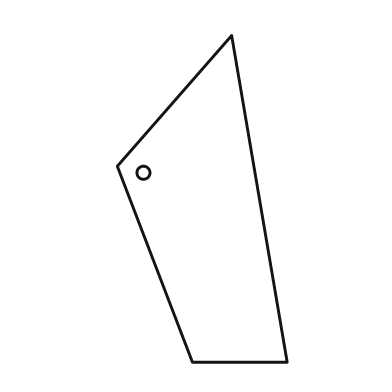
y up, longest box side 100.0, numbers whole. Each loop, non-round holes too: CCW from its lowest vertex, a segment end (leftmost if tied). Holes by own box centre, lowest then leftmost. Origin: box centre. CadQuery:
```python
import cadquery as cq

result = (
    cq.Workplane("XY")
    .moveTo(-3.0, -50.0)
    .lineTo(26.0, -50.0)
    .lineTo(9.0, 50.0)
    .lineTo(-26.0, 10.0)
    .close()
    .moveTo(-18.0, 8.0)
    .circle(2.0)
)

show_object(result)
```